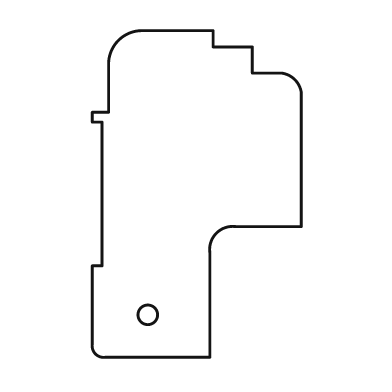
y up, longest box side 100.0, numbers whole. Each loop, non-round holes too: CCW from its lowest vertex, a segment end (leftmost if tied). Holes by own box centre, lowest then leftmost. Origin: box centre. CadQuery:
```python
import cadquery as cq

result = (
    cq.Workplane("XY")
    .moveTo(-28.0, -50.0)
    .lineTo(4.0, -50.0)
    .lineTo(4.0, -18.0)
    .threePointArc((6.0, -12.0), (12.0, -10.0))
    .lineTo(32.0, -10.0)
    .lineTo(32.0, 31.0)
    .threePointArc((30.0, 35.0), (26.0, 37.0))
    .lineTo(17.0, 37.0)
    .lineTo(17.0, 45.0)
    .lineTo(5.0, 45.0)
    .lineTo(5.0, 50.0)
    .lineTo(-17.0, 50.0)
    .threePointArc((-24.0, 47.0), (-27.0, 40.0))
    .lineTo(-27.0, 25.0)
    .lineTo(-32.0, 25.0)
    .lineTo(-32.0, 22.0)
    .lineTo(-29.0, 22.0)
    .lineTo(-29.0, -22.0)
    .lineTo(-32.0, -22.0)
    .lineTo(-32.0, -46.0)
    .threePointArc((-31.0, -49.0), (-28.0, -50.0))
    .close()
    .moveTo(-15.0, -37.0)
    .circle(3.0)
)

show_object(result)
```